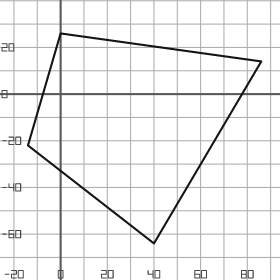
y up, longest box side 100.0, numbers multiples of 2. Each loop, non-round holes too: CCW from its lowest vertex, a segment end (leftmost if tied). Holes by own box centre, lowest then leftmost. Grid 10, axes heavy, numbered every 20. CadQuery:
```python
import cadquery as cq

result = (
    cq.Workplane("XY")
    .moveTo(40.0, -64.0)
    .lineTo(86.0, 14.0)
    .lineTo(0.0, 26.0)
    .lineTo(-14.0, -22.0)
    .close()
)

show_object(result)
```